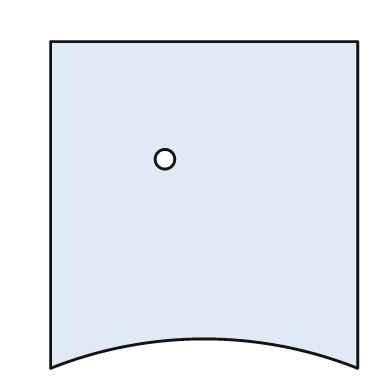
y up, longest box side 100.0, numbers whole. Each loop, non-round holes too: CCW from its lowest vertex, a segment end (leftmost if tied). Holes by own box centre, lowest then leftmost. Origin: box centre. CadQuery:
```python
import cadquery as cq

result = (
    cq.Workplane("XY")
    .moveTo(-47.0, -50.0)
    .threePointArc((0.0, -41.0), (47.0, -50.0))
    .lineTo(47.0, 50.0)
    .lineTo(-47.0, 50.0)
    .close()
    .moveTo(-12.0, 14.0)
    .circle(3.0)
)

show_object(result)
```